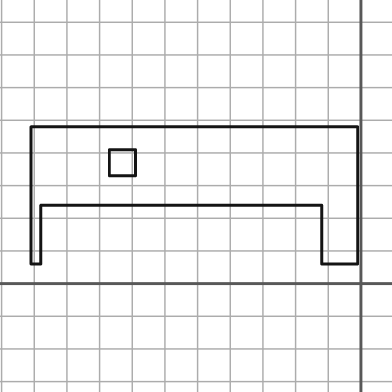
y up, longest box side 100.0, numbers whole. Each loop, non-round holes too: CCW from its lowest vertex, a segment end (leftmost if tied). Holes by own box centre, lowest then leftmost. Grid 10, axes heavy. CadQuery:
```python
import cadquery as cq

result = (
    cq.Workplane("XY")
    .moveTo(-101.0, 6.0)
    .lineTo(-98.0, 6.0)
    .lineTo(-98.0, 24.0)
    .lineTo(-12.0, 24.0)
    .lineTo(-12.0, 6.0)
    .lineTo(-1.0, 6.0)
    .lineTo(-1.0, 48.0)
    .lineTo(-101.0, 48.0)
    .close()
    .moveTo(-77.0, 33.0)
    .lineTo(-69.0, 33.0)
    .lineTo(-69.0, 41.0)
    .lineTo(-77.0, 41.0)
    .close()
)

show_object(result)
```